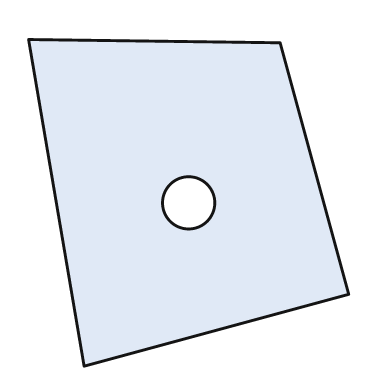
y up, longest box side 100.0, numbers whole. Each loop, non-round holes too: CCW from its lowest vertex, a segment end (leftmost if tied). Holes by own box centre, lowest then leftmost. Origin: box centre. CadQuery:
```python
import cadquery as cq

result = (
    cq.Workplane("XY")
    .moveTo(-32.0, -50.0)
    .lineTo(49.0, -28.0)
    .lineTo(28.0, 49.0)
    .lineTo(-49.0, 50.0)
    .close()
    .moveTo(0.0, 0.0)
    .circle(8.0)
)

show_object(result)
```